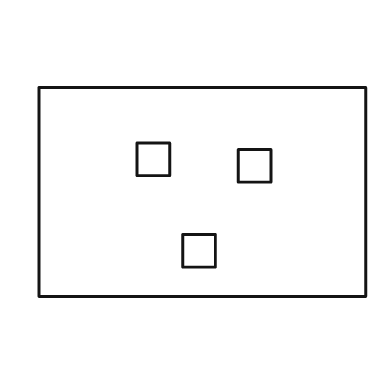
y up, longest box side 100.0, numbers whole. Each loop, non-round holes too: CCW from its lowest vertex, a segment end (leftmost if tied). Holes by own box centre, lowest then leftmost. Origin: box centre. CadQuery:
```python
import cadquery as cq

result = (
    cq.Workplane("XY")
    .moveTo(-50.0, -32.0)
    .lineTo(50.0, -32.0)
    .lineTo(50.0, 32.0)
    .lineTo(-50.0, 32.0)
    .close()
    .moveTo(-6.0, -23.0)
    .lineTo(4.0, -23.0)
    .lineTo(4.0, -13.0)
    .lineTo(-6.0, -13.0)
    .close()
    .moveTo(11.0, 3.0)
    .lineTo(21.0, 3.0)
    .lineTo(21.0, 13.0)
    .lineTo(11.0, 13.0)
    .close()
    .moveTo(-20.0, 5.0)
    .lineTo(-10.0, 5.0)
    .lineTo(-10.0, 15.0)
    .lineTo(-20.0, 15.0)
    .close()
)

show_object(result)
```